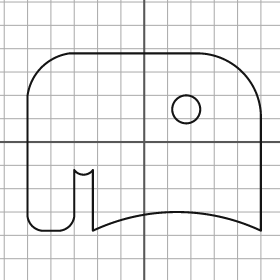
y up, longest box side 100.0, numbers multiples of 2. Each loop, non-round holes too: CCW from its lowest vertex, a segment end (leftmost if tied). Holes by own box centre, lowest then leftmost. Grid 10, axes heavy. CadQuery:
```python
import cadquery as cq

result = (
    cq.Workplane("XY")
    .moveTo(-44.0, -38.0)
    .lineTo(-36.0, -38.0)
    .threePointArc((-32.0, -36.0), (-30.0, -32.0))
    .lineTo(-30.0, -12.0)
    .threePointArc((-26.0, -14.0), (-22.0, -12.0))
    .lineTo(-22.0, -38.0)
    .threePointArc((14.0, -30.0), (50.0, -38.0))
    .lineTo(50.0, 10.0)
    .threePointArc((42.0, 30.0), (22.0, 38.0))
    .lineTo(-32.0, 38.0)
    .threePointArc((-44.0, 32.0), (-50.0, 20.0))
    .lineTo(-50.0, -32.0)
    .threePointArc((-48.0, -36.0), (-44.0, -38.0))
    .close()
    .moveTo(18.0, 14.0)
    .circle(6.0)
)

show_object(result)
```